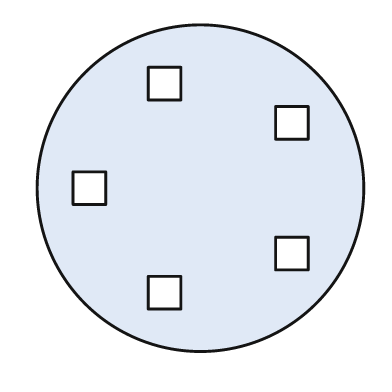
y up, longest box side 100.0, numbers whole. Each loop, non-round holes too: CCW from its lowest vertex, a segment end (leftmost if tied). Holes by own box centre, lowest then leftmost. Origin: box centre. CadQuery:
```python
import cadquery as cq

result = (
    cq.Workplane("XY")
    .moveTo(0.0, 0.0)
    .circle(50.0)
    .moveTo(-16.0, -37.0)
    .lineTo(-6.0, -37.0)
    .lineTo(-6.0, -27.0)
    .lineTo(-16.0, -27.0)
    .close()
    .moveTo(23.0, -25.0)
    .lineTo(33.0, -25.0)
    .lineTo(33.0, -15.0)
    .lineTo(23.0, -15.0)
    .close()
    .moveTo(-39.0, -5.0)
    .lineTo(-29.0, -5.0)
    .lineTo(-29.0, 5.0)
    .lineTo(-39.0, 5.0)
    .close()
    .moveTo(23.0, 15.0)
    .lineTo(33.0, 15.0)
    .lineTo(33.0, 25.0)
    .lineTo(23.0, 25.0)
    .close()
    .moveTo(-16.0, 27.0)
    .lineTo(-6.0, 27.0)
    .lineTo(-6.0, 37.0)
    .lineTo(-16.0, 37.0)
    .close()
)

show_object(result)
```